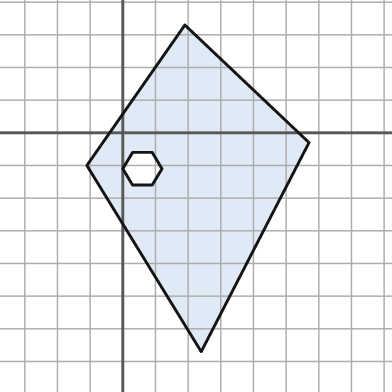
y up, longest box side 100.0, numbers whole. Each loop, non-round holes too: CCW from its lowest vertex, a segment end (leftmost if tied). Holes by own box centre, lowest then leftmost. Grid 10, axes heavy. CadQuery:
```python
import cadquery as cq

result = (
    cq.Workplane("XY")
    .moveTo(24.0, -67.0)
    .lineTo(57.0, -3.0)
    .lineTo(19.0, 33.0)
    .lineTo(-11.0, -10.0)
    .close()
    .moveTo(3.0, -16.0)
    .lineTo(9.0, -16.0)
    .lineTo(12.0, -11.0)
    .lineTo(9.0, -6.0)
    .lineTo(3.0, -6.0)
    .lineTo(0.0, -11.0)
    .close()
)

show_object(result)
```